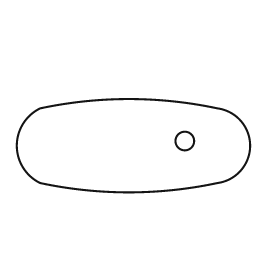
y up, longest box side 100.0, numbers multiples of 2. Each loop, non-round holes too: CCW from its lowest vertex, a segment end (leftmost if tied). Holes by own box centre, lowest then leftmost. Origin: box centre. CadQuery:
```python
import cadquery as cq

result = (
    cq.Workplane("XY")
    .moveTo(-40.0, -16.0)
    .threePointArc((-2.0, -20.0), (36.0, -16.0))
    .threePointArc((50.0, 0.0), (36.0, 16.0))
    .threePointArc((-2.0, 20.0), (-40.0, 16.0))
    .threePointArc((-50.0, 0.0), (-40.0, -16.0))
    .close()
    .moveTo(22.0, 2.0)
    .circle(4.0)
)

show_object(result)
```